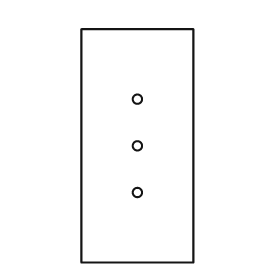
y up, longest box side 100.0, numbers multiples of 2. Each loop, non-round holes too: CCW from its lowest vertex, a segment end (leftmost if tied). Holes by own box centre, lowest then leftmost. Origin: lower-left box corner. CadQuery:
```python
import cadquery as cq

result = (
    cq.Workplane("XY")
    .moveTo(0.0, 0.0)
    .lineTo(48.0, 0.0)
    .lineTo(48.0, 100.0)
    .lineTo(0.0, 100.0)
    .close()
    .moveTo(24.0, 30.0)
    .circle(2.0)
    .moveTo(24.0, 50.0)
    .circle(2.0)
    .moveTo(24.0, 70.0)
    .circle(2.0)
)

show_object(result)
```